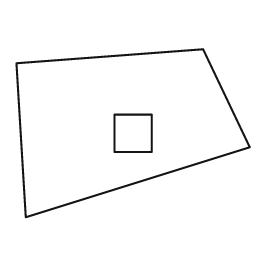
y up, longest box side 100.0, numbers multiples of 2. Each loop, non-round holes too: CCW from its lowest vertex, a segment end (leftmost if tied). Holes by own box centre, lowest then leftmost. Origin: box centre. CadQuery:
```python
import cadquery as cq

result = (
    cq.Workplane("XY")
    .moveTo(-46.0, -36.0)
    .lineTo(50.0, -6.0)
    .lineTo(30.0, 36.0)
    .lineTo(-50.0, 30.0)
    .close()
    .moveTo(-8.0, -8.0)
    .lineTo(8.0, -8.0)
    .lineTo(8.0, 8.0)
    .lineTo(-8.0, 8.0)
    .close()
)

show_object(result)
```